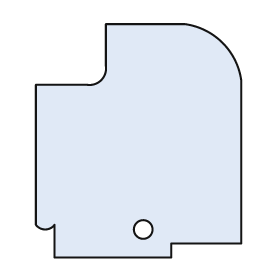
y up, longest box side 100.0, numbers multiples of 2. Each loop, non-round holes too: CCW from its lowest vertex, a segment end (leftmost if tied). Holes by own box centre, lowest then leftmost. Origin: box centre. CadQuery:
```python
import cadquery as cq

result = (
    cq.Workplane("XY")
    .moveTo(-36.0, -50.0)
    .lineTo(14.0, -50.0)
    .lineTo(14.0, -44.0)
    .lineTo(44.0, -44.0)
    .lineTo(44.0, 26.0)
    .threePointArc((36.0, 42.0), (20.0, 50.0))
    .lineTo(-14.0, 50.0)
    .lineTo(-14.0, 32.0)
    .threePointArc((-16.0, 26.0), (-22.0, 24.0))
    .lineTo(-44.0, 24.0)
    .lineTo(-44.0, -36.0)
    .threePointArc((-40.0, -38.0), (-36.0, -36.0))
    .close()
    .moveTo(2.0, -38.0)
    .circle(4.0)
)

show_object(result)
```